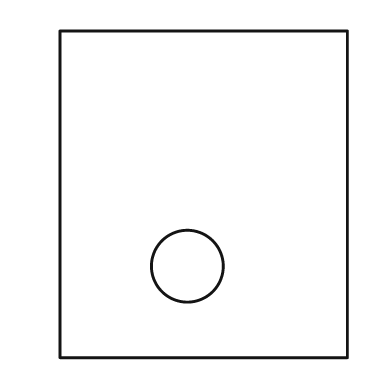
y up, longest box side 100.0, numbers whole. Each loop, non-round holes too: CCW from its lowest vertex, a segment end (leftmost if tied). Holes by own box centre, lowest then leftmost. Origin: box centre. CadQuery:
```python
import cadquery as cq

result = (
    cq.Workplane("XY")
    .moveTo(-44.0, -50.0)
    .lineTo(44.0, -50.0)
    .lineTo(44.0, 50.0)
    .lineTo(-44.0, 50.0)
    .close()
    .moveTo(-5.0, -22.0)
    .circle(11.0)
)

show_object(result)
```